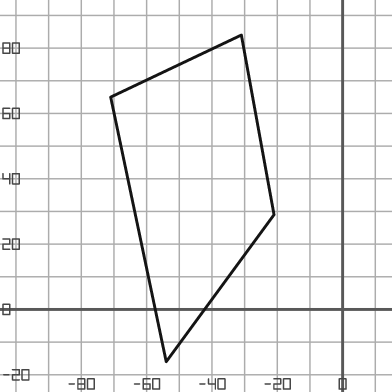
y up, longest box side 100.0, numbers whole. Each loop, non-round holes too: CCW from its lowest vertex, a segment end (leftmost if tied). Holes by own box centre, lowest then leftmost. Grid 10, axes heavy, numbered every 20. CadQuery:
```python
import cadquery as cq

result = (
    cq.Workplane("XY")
    .moveTo(-54.0, -16.0)
    .lineTo(-21.0, 29.0)
    .lineTo(-31.0, 84.0)
    .lineTo(-71.0, 65.0)
    .close()
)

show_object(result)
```